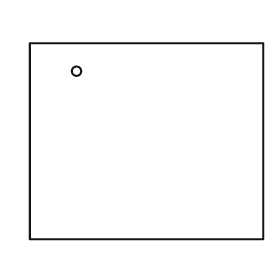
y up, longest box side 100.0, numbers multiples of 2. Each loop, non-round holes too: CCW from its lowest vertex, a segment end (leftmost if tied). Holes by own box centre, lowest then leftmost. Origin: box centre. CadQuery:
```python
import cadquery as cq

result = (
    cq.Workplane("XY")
    .moveTo(-50.0, -42.0)
    .lineTo(50.0, -42.0)
    .lineTo(50.0, 42.0)
    .lineTo(-50.0, 42.0)
    .close()
    .moveTo(-30.0, 30.0)
    .circle(2.0)
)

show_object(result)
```